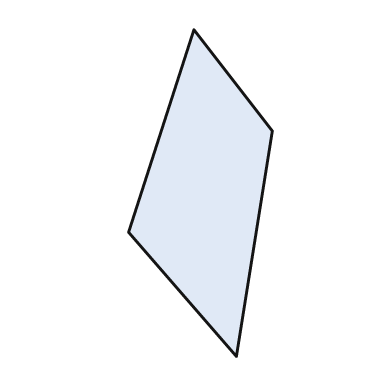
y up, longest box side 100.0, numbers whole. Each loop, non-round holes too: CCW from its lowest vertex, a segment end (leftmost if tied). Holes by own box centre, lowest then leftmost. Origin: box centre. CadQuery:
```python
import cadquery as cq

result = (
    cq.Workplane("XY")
    .moveTo(11.0, -50.0)
    .lineTo(22.0, 19.0)
    .lineTo(-2.0, 50.0)
    .lineTo(-22.0, -12.0)
    .close()
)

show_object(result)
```